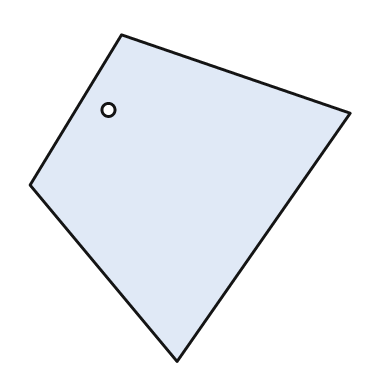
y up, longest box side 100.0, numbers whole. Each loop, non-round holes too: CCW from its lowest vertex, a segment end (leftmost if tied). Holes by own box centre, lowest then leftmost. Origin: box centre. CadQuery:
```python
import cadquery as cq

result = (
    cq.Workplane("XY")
    .moveTo(-4.0, -50.0)
    .lineTo(49.0, 26.0)
    .lineTo(-21.0, 50.0)
    .lineTo(-49.0, 4.0)
    .close()
    .moveTo(-25.0, 27.0)
    .circle(2.0)
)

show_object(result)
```